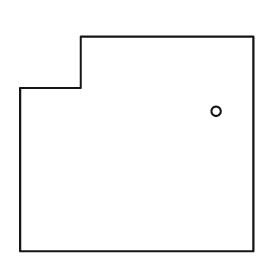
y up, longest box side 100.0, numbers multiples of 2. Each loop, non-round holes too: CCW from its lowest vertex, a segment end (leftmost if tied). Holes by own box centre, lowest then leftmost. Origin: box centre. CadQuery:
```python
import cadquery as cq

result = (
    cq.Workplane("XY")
    .moveTo(-50.0, -46.0)
    .lineTo(50.0, -46.0)
    .lineTo(50.0, 46.0)
    .lineTo(-24.0, 46.0)
    .lineTo(-24.0, 24.0)
    .lineTo(-50.0, 24.0)
    .close()
    .moveTo(34.0, 14.0)
    .circle(2.0)
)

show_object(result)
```